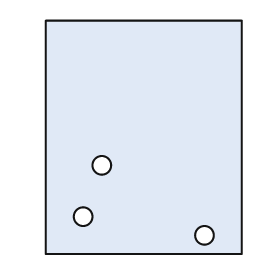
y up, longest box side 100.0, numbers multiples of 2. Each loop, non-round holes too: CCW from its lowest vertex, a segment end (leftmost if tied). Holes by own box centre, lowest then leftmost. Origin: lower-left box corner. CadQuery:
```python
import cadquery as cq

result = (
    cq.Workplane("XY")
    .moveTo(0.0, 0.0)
    .lineTo(84.0, 0.0)
    .lineTo(84.0, 100.0)
    .lineTo(0.0, 100.0)
    .close()
    .moveTo(68.0, 8.0)
    .circle(4.0)
    .moveTo(16.0, 16.0)
    .circle(4.0)
    .moveTo(24.0, 38.0)
    .circle(4.0)
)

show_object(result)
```